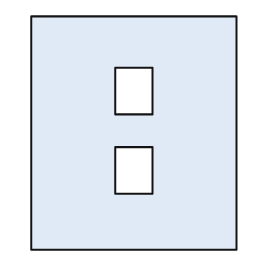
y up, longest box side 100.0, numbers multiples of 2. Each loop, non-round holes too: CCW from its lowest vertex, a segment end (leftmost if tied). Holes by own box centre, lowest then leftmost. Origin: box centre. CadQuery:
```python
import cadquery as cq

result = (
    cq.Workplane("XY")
    .moveTo(-44.0, -50.0)
    .lineTo(44.0, -50.0)
    .lineTo(44.0, 50.0)
    .lineTo(-44.0, 50.0)
    .close()
    .moveTo(-8.0, -26.0)
    .lineTo(8.0, -26.0)
    .lineTo(8.0, -6.0)
    .lineTo(-8.0, -6.0)
    .close()
    .moveTo(-8.0, 8.0)
    .lineTo(8.0, 8.0)
    .lineTo(8.0, 28.0)
    .lineTo(-8.0, 28.0)
    .close()
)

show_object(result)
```